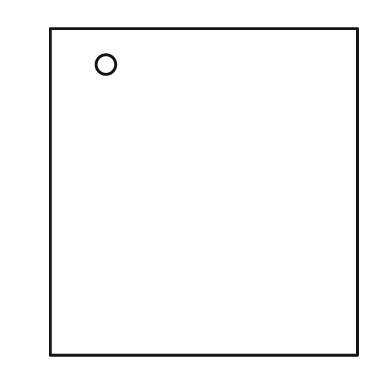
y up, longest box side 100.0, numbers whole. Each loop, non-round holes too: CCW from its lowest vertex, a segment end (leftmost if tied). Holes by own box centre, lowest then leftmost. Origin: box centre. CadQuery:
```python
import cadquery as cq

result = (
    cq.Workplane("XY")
    .moveTo(-47.0, -50.0)
    .lineTo(47.0, -50.0)
    .lineTo(47.0, 50.0)
    .lineTo(-47.0, 50.0)
    .close()
    .moveTo(-30.0, 39.0)
    .circle(3.0)
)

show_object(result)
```